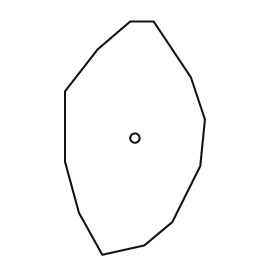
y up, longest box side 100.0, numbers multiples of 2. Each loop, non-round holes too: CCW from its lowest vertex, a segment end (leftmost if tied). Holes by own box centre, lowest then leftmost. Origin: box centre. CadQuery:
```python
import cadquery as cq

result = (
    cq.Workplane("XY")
    .moveTo(-14.0, -50.0)
    .lineTo(4.0, -46.0)
    .lineTo(16.0, -36.0)
    .lineTo(28.0, -12.0)
    .lineTo(30.0, 8.0)
    .lineTo(24.0, 26.0)
    .lineTo(8.0, 50.0)
    .lineTo(-2.0, 50.0)
    .lineTo(-16.0, 38.0)
    .lineTo(-30.0, 20.0)
    .lineTo(-30.0, -10.0)
    .lineTo(-24.0, -32.0)
    .close()
    .moveTo(0.0, 0.0)
    .circle(2.0)
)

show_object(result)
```